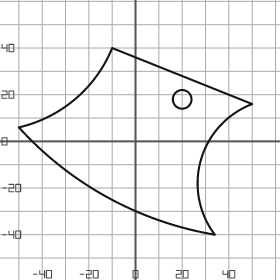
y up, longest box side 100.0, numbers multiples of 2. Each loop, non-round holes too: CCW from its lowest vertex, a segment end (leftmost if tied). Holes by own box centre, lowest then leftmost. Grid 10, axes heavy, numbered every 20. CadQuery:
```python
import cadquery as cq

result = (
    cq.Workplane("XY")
    .moveTo(34.0, -40.0)
    .threePointArc((28.0, -8.0), (50.0, 16.0))
    .lineTo(-10.0, 40.0)
    .threePointArc((-26.0, 18.0), (-50.0, 6.0))
    .threePointArc((-12.0, -24.0), (34.0, -40.0))
    .close()
    .moveTo(20.0, 18.0)
    .circle(4.0)
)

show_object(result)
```